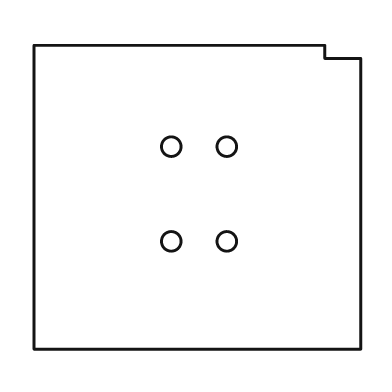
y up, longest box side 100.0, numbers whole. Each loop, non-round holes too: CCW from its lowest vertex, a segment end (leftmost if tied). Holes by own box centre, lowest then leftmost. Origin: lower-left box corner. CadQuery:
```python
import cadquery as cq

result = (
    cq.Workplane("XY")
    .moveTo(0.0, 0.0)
    .lineTo(100.0, 0.0)
    .lineTo(100.0, 89.0)
    .lineTo(89.0, 89.0)
    .lineTo(89.0, 93.0)
    .lineTo(0.0, 93.0)
    .close()
    .moveTo(42.0, 33.0)
    .circle(3.0)
    .moveTo(59.0, 33.0)
    .circle(3.0)
    .moveTo(42.0, 62.0)
    .circle(3.0)
    .moveTo(59.0, 62.0)
    .circle(3.0)
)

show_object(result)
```